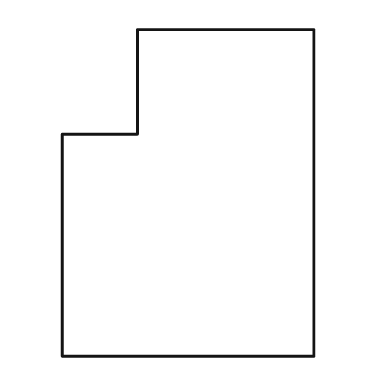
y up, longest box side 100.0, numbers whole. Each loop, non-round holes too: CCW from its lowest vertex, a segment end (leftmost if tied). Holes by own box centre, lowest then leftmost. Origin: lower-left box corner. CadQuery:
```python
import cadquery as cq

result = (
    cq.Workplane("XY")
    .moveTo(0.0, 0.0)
    .lineTo(77.0, 0.0)
    .lineTo(77.0, 100.0)
    .lineTo(23.0, 100.0)
    .lineTo(23.0, 68.0)
    .lineTo(0.0, 68.0)
    .close()
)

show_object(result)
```